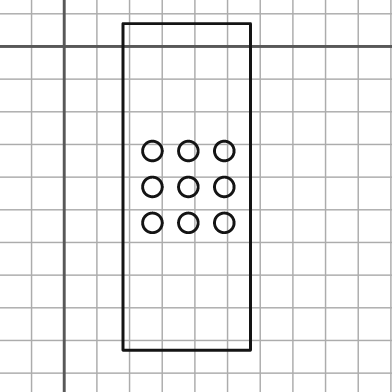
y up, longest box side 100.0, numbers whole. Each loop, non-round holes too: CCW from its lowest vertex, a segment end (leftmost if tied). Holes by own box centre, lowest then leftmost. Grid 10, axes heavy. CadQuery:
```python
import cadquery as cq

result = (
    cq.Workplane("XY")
    .moveTo(18.0, -93.0)
    .lineTo(57.0, -93.0)
    .lineTo(57.0, 7.0)
    .lineTo(18.0, 7.0)
    .close()
    .moveTo(27.0, -54.0)
    .circle(3.0)
    .moveTo(38.0, -54.0)
    .circle(3.0)
    .moveTo(49.0, -54.0)
    .circle(3.0)
    .moveTo(27.0, -43.0)
    .circle(3.0)
    .moveTo(38.0, -43.0)
    .circle(3.0)
    .moveTo(49.0, -43.0)
    .circle(3.0)
    .moveTo(27.0, -32.0)
    .circle(3.0)
    .moveTo(38.0, -32.0)
    .circle(3.0)
    .moveTo(49.0, -32.0)
    .circle(3.0)
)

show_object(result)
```